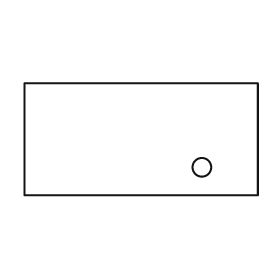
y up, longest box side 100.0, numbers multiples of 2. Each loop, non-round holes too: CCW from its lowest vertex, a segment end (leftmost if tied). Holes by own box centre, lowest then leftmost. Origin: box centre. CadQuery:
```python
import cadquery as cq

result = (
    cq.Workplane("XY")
    .moveTo(-50.0, -24.0)
    .lineTo(50.0, -24.0)
    .lineTo(50.0, 24.0)
    .lineTo(-50.0, 24.0)
    .close()
    .moveTo(26.0, -12.0)
    .circle(4.0)
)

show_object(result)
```